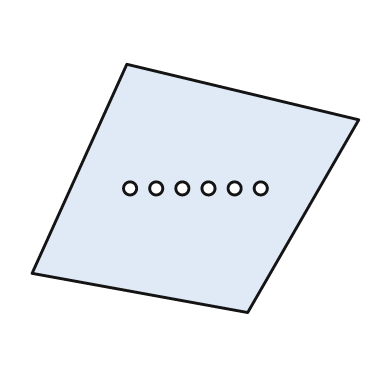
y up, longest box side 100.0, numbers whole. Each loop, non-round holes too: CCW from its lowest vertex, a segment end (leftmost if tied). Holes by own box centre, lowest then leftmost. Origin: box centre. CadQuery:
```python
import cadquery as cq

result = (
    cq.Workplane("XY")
    .moveTo(16.0, -38.0)
    .lineTo(50.0, 21.0)
    .lineTo(-21.0, 38.0)
    .lineTo(-50.0, -26.0)
    .close()
    .moveTo(-20.0, 0.0)
    .circle(2.0)
    .moveTo(-12.0, 0.0)
    .circle(2.0)
    .moveTo(-4.0, 0.0)
    .circle(2.0)
    .moveTo(4.0, 0.0)
    .circle(2.0)
    .moveTo(12.0, 0.0)
    .circle(2.0)
    .moveTo(20.0, 0.0)
    .circle(2.0)
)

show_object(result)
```